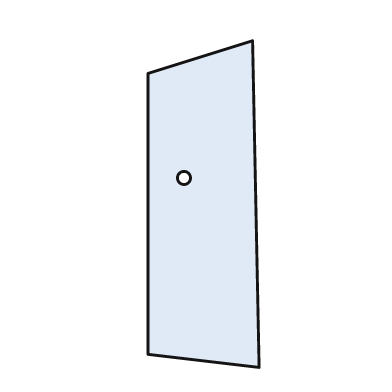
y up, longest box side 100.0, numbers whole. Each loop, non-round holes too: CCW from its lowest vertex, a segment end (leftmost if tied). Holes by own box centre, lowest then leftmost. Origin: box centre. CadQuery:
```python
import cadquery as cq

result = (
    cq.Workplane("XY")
    .moveTo(17.0, -50.0)
    .lineTo(15.0, 50.0)
    .lineTo(-17.0, 40.0)
    .lineTo(-17.0, -46.0)
    .close()
    .moveTo(-6.0, 8.0)
    .circle(2.0)
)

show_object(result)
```